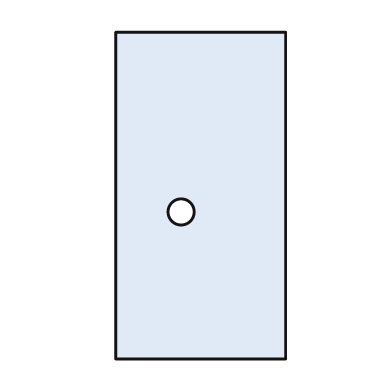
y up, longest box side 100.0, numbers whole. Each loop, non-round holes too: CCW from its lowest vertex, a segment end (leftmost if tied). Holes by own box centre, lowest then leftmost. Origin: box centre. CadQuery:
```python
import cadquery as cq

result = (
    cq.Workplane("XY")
    .moveTo(-26.0, -50.0)
    .lineTo(26.0, -50.0)
    .lineTo(26.0, 50.0)
    .lineTo(-26.0, 50.0)
    .close()
    .moveTo(-6.0, -5.0)
    .circle(4.0)
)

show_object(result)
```